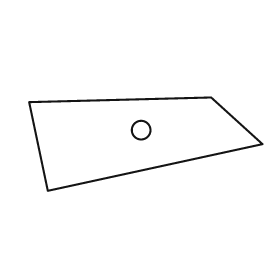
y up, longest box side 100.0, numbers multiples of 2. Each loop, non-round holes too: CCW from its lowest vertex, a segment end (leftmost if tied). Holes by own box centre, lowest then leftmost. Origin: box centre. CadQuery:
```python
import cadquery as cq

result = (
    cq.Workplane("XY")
    .moveTo(-42.0, -20.0)
    .lineTo(50.0, 0.0)
    .lineTo(28.0, 20.0)
    .lineTo(-50.0, 18.0)
    .close()
    .moveTo(-2.0, 6.0)
    .circle(4.0)
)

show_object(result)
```